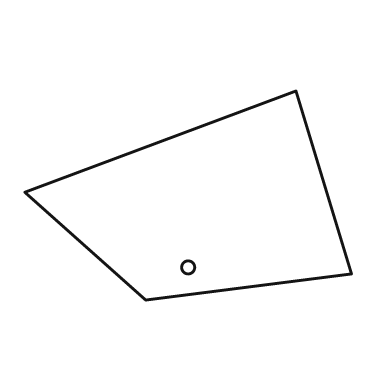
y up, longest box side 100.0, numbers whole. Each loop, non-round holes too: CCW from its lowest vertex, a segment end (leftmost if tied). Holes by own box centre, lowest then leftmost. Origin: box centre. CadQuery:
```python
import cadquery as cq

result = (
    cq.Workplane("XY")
    .moveTo(-13.0, -32.0)
    .lineTo(50.0, -24.0)
    .lineTo(33.0, 32.0)
    .lineTo(-50.0, 1.0)
    .close()
    .moveTo(0.0, -22.0)
    .circle(2.0)
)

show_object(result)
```